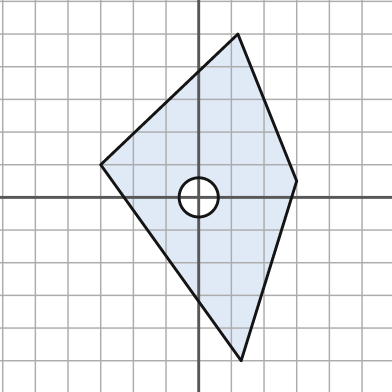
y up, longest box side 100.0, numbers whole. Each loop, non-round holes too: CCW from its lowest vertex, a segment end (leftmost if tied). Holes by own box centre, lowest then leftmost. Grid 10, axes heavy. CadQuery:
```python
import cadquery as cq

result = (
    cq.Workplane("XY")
    .moveTo(13.0, -50.0)
    .lineTo(30.0, 5.0)
    .lineTo(12.0, 50.0)
    .lineTo(-30.0, 10.0)
    .close()
    .moveTo(0.0, 0.0)
    .circle(6.0)
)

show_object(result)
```